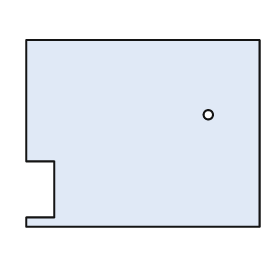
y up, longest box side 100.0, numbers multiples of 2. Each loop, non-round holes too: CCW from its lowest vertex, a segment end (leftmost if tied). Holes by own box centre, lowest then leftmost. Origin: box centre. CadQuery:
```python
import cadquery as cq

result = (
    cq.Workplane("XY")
    .moveTo(-50.0, -40.0)
    .lineTo(50.0, -40.0)
    .lineTo(50.0, 40.0)
    .lineTo(-50.0, 40.0)
    .lineTo(-50.0, -12.0)
    .lineTo(-38.0, -12.0)
    .lineTo(-38.0, -36.0)
    .lineTo(-50.0, -36.0)
    .close()
    .moveTo(28.0, 8.0)
    .circle(2.0)
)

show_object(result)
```